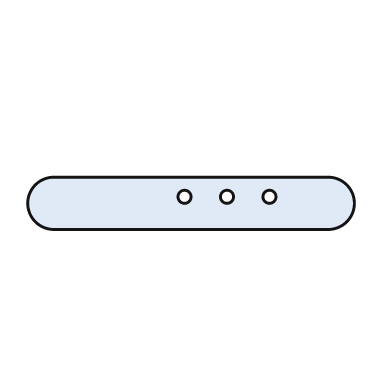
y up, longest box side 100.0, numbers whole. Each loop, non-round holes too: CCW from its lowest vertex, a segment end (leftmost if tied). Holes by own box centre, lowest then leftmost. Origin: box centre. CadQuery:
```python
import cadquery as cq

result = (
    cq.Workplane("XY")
    .moveTo(-42.0, -8.0)
    .lineTo(42.0, -8.0)
    .threePointArc((50.0, 0.0), (42.0, 8.0))
    .lineTo(-42.0, 8.0)
    .threePointArc((-50.0, 0.0), (-42.0, -8.0))
    .close()
    .moveTo(-2.0, 2.0)
    .circle(2.0)
    .moveTo(11.0, 2.0)
    .circle(2.0)
    .moveTo(24.0, 2.0)
    .circle(2.0)
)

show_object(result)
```